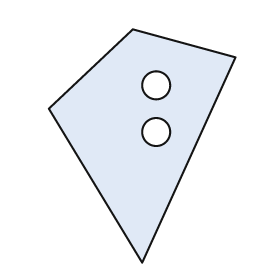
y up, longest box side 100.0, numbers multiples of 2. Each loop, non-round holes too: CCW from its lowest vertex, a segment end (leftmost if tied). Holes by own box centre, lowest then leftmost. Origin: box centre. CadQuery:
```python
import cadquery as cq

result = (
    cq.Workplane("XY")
    .moveTo(0.0, -50.0)
    .lineTo(40.0, 38.0)
    .lineTo(-4.0, 50.0)
    .lineTo(-40.0, 16.0)
    .close()
    .moveTo(6.0, 6.0)
    .circle(6.0)
    .moveTo(6.0, 26.0)
    .circle(6.0)
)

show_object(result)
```